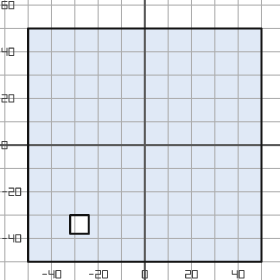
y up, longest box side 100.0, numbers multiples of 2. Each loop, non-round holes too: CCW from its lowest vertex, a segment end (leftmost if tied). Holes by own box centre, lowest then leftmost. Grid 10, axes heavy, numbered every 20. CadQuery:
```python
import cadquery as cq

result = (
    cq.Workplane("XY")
    .moveTo(-50.0, -50.0)
    .lineTo(50.0, -50.0)
    .lineTo(50.0, 50.0)
    .lineTo(-50.0, 50.0)
    .close()
    .moveTo(-32.0, -38.0)
    .lineTo(-24.0, -38.0)
    .lineTo(-24.0, -30.0)
    .lineTo(-32.0, -30.0)
    .close()
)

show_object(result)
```